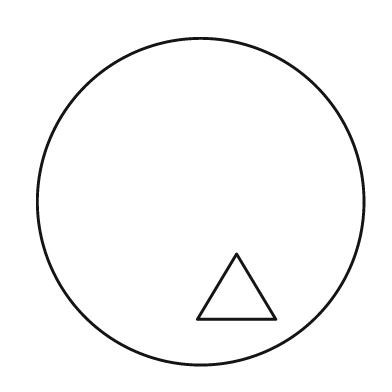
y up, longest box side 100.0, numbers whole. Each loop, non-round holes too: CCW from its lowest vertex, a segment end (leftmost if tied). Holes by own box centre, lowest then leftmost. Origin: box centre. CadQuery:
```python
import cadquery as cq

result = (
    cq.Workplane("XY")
    .moveTo(0.0, 0.0)
    .circle(50.0)
    .moveTo(-1.0, -36.0)
    .lineTo(23.0, -36.0)
    .lineTo(11.0, -16.0)
    .close()
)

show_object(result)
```